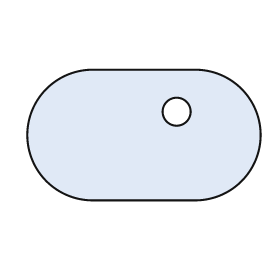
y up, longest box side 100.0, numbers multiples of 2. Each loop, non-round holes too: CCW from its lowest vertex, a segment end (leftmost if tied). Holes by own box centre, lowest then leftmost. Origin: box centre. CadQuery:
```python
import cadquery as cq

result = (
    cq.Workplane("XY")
    .moveTo(-22.0, -28.0)
    .lineTo(22.0, -28.0)
    .threePointArc((50.0, 0.0), (22.0, 28.0))
    .lineTo(-22.0, 28.0)
    .threePointArc((-50.0, 0.0), (-22.0, -28.0))
    .close()
    .moveTo(14.0, 10.0)
    .circle(6.0)
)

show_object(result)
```